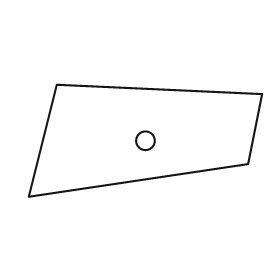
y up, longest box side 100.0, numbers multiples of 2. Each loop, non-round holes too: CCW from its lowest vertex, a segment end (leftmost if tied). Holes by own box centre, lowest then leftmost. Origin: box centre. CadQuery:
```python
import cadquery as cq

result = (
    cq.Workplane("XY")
    .moveTo(-50.0, -24.0)
    .lineTo(44.0, -10.0)
    .lineTo(50.0, 20.0)
    .lineTo(-38.0, 24.0)
    .close()
    .moveTo(0.0, 0.0)
    .circle(4.0)
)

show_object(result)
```